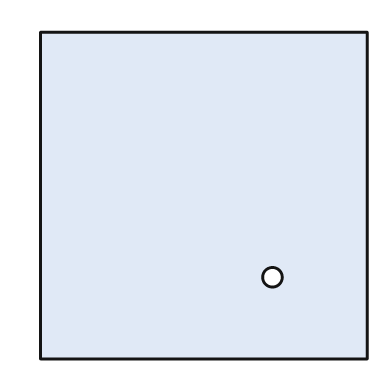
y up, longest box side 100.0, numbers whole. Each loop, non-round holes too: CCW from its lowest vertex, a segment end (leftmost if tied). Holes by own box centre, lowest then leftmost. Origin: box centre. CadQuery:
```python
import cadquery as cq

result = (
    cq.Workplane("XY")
    .moveTo(-50.0, -50.0)
    .lineTo(50.0, -50.0)
    .lineTo(50.0, 50.0)
    .lineTo(-50.0, 50.0)
    .close()
    .moveTo(21.0, -25.0)
    .circle(3.0)
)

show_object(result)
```